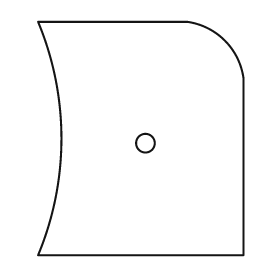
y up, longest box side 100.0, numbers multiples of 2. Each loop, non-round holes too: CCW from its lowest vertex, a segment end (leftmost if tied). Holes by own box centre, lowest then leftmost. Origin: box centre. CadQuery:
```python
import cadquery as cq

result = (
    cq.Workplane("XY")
    .moveTo(-44.0, -50.0)
    .lineTo(44.0, -50.0)
    .lineTo(44.0, 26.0)
    .threePointArc((36.0, 42.0), (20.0, 50.0))
    .lineTo(-44.0, 50.0)
    .threePointArc((-34.0, 0.0), (-44.0, -50.0))
    .close()
    .moveTo(2.0, -2.0)
    .circle(4.0)
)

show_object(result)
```